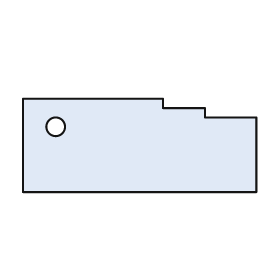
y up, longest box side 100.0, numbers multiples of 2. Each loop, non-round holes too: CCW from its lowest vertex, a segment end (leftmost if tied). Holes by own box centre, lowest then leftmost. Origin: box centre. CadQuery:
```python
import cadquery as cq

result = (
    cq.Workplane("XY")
    .moveTo(-50.0, -20.0)
    .lineTo(50.0, -20.0)
    .lineTo(50.0, 12.0)
    .lineTo(28.0, 12.0)
    .lineTo(28.0, 16.0)
    .lineTo(10.0, 16.0)
    .lineTo(10.0, 20.0)
    .lineTo(-50.0, 20.0)
    .close()
    .moveTo(-36.0, 8.0)
    .circle(4.0)
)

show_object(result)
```